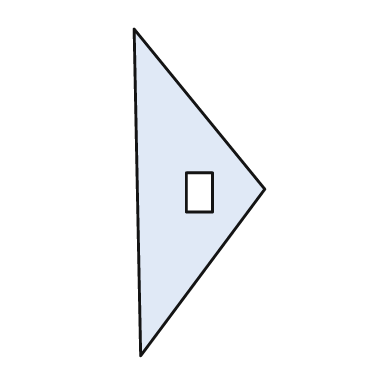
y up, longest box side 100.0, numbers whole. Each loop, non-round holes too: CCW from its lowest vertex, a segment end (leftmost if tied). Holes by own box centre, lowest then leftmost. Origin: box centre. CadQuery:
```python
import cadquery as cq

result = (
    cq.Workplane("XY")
    .moveTo(-18.0, -50.0)
    .lineTo(20.0, 1.0)
    .lineTo(-20.0, 50.0)
    .close()
    .moveTo(-4.0, -6.0)
    .lineTo(4.0, -6.0)
    .lineTo(4.0, 6.0)
    .lineTo(-4.0, 6.0)
    .close()
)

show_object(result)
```